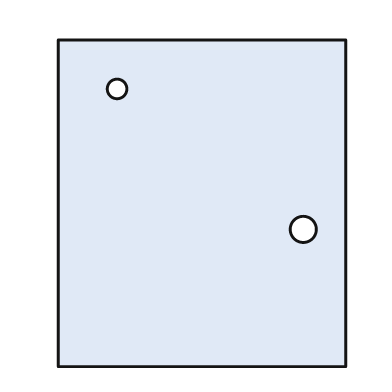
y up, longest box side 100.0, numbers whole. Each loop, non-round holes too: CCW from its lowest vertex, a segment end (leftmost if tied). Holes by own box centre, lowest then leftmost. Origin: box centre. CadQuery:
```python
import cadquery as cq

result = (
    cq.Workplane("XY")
    .moveTo(-44.0, -50.0)
    .lineTo(44.0, -50.0)
    .lineTo(44.0, 50.0)
    .lineTo(-44.0, 50.0)
    .close()
    .moveTo(31.0, -8.0)
    .circle(4.0)
    .moveTo(-26.0, 35.0)
    .circle(3.0)
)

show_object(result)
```